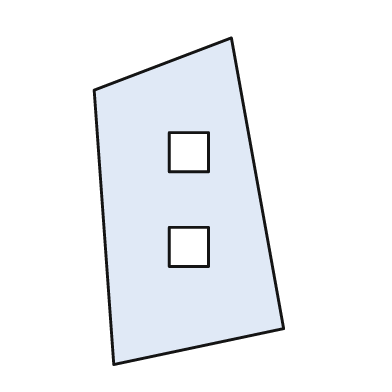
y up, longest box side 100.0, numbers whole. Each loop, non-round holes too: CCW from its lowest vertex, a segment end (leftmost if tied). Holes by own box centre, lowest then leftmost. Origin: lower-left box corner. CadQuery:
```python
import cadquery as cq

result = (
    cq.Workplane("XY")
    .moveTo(6.0, 0.0)
    .lineTo(58.0, 11.0)
    .lineTo(42.0, 100.0)
    .lineTo(0.0, 84.0)
    .close()
    .moveTo(23.0, 30.0)
    .lineTo(35.0, 30.0)
    .lineTo(35.0, 42.0)
    .lineTo(23.0, 42.0)
    .close()
    .moveTo(23.0, 59.0)
    .lineTo(35.0, 59.0)
    .lineTo(35.0, 71.0)
    .lineTo(23.0, 71.0)
    .close()
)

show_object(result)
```